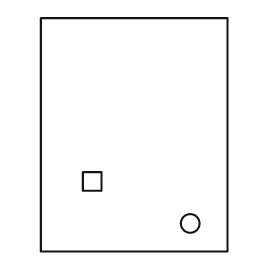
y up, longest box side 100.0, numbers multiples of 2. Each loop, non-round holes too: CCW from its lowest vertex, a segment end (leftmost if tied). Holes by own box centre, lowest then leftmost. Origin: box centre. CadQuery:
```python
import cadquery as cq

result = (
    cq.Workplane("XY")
    .moveTo(-40.0, -50.0)
    .lineTo(40.0, -50.0)
    .lineTo(40.0, 50.0)
    .lineTo(-40.0, 50.0)
    .close()
    .moveTo(24.0, -38.0)
    .circle(4.0)
    .moveTo(-22.0, -24.0)
    .lineTo(-14.0, -24.0)
    .lineTo(-14.0, -16.0)
    .lineTo(-22.0, -16.0)
    .close()
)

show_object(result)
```